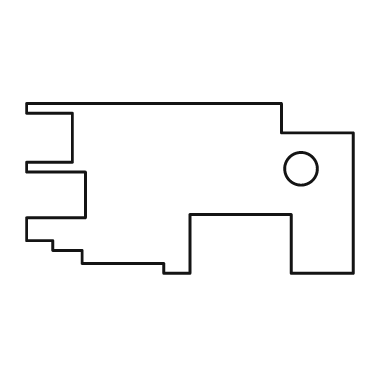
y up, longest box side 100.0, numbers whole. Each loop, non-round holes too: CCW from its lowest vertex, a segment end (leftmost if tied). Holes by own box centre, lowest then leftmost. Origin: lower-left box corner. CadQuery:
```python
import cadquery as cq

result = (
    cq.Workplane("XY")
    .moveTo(42.0, 0.0)
    .lineTo(50.0, 0.0)
    .lineTo(50.0, 18.0)
    .lineTo(81.0, 18.0)
    .lineTo(81.0, 0.0)
    .lineTo(100.0, 0.0)
    .lineTo(100.0, 43.0)
    .lineTo(78.0, 43.0)
    .lineTo(78.0, 52.0)
    .lineTo(0.0, 52.0)
    .lineTo(0.0, 49.0)
    .lineTo(14.0, 49.0)
    .lineTo(14.0, 34.0)
    .lineTo(0.0, 34.0)
    .lineTo(0.0, 31.0)
    .lineTo(18.0, 31.0)
    .lineTo(18.0, 17.0)
    .lineTo(0.0, 17.0)
    .lineTo(0.0, 10.0)
    .lineTo(8.0, 10.0)
    .lineTo(8.0, 7.0)
    .lineTo(17.0, 7.0)
    .lineTo(17.0, 3.0)
    .lineTo(42.0, 3.0)
    .close()
    .moveTo(84.0, 32.0)
    .circle(5.0)
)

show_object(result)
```